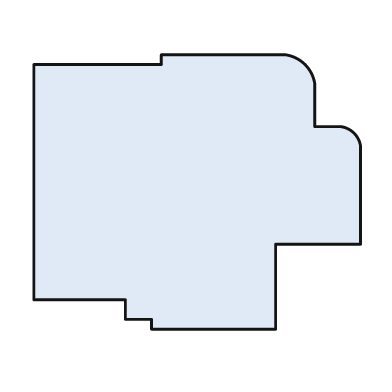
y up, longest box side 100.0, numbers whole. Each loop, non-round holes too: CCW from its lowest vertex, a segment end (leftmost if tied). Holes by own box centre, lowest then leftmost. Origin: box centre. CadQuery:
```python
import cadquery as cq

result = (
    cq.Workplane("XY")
    .moveTo(-14.0, -42.0)
    .lineTo(24.0, -42.0)
    .lineTo(24.0, -16.0)
    .lineTo(50.0, -16.0)
    .lineTo(50.0, 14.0)
    .threePointArc((48.0, 18.0), (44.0, 20.0))
    .lineTo(36.0, 20.0)
    .lineTo(36.0, 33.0)
    .threePointArc((33.0, 39.0), (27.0, 42.0))
    .lineTo(-11.0, 42.0)
    .lineTo(-11.0, 39.0)
    .lineTo(-50.0, 39.0)
    .lineTo(-50.0, -33.0)
    .lineTo(-22.0, -33.0)
    .lineTo(-22.0, -39.0)
    .lineTo(-14.0, -39.0)
    .close()
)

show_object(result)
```